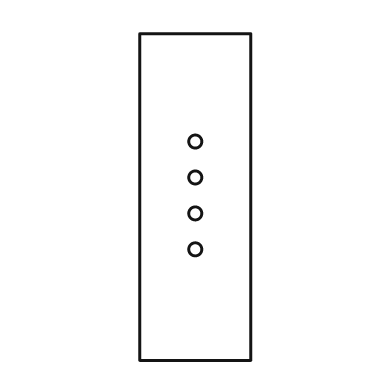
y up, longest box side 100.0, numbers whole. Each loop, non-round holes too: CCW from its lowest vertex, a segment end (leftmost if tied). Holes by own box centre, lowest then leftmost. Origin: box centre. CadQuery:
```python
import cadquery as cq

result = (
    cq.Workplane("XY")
    .moveTo(-17.0, -50.0)
    .lineTo(17.0, -50.0)
    .lineTo(17.0, 50.0)
    .lineTo(-17.0, 50.0)
    .close()
    .moveTo(0.0, -16.0)
    .circle(2.0)
    .moveTo(0.0, -5.0)
    .circle(2.0)
    .moveTo(0.0, 6.0)
    .circle(2.0)
    .moveTo(0.0, 17.0)
    .circle(2.0)
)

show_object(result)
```